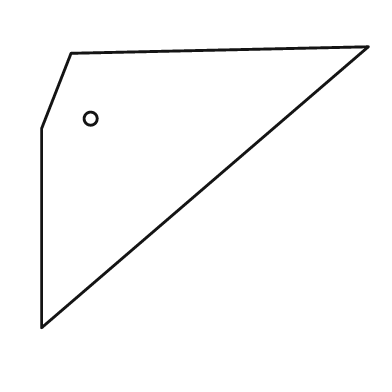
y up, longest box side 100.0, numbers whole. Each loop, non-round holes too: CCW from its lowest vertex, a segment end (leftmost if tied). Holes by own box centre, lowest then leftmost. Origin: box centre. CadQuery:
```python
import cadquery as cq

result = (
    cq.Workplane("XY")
    .moveTo(-50.0, -43.0)
    .lineTo(50.0, 43.0)
    .lineTo(-41.0, 41.0)
    .lineTo(-50.0, 18.0)
    .close()
    .moveTo(-35.0, 21.0)
    .circle(2.0)
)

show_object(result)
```